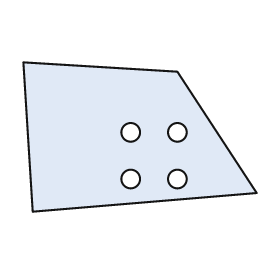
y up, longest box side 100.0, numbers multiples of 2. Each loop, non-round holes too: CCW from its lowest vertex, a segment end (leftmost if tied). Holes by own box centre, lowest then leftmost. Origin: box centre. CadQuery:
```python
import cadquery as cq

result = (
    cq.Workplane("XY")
    .moveTo(-46.0, -32.0)
    .lineTo(50.0, -24.0)
    .lineTo(16.0, 28.0)
    .lineTo(-50.0, 32.0)
    .close()
    .moveTo(-4.0, -18.0)
    .circle(4.0)
    .moveTo(16.0, -18.0)
    .circle(4.0)
    .moveTo(-4.0, 2.0)
    .circle(4.0)
    .moveTo(16.0, 2.0)
    .circle(4.0)
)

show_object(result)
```